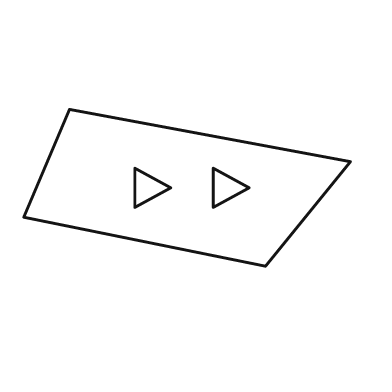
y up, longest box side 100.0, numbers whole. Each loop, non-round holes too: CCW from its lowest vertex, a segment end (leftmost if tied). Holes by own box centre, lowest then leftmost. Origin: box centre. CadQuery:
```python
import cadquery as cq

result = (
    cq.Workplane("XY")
    .moveTo(24.0, -24.0)
    .lineTo(50.0, 8.0)
    .lineTo(-36.0, 24.0)
    .lineTo(-50.0, -9.0)
    .close()
    .moveTo(-16.0, -6.0)
    .lineTo(-5.0, 0.0)
    .lineTo(-16.0, 6.0)
    .close()
    .moveTo(8.0, -6.0)
    .lineTo(19.0, 0.0)
    .lineTo(8.0, 6.0)
    .close()
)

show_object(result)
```